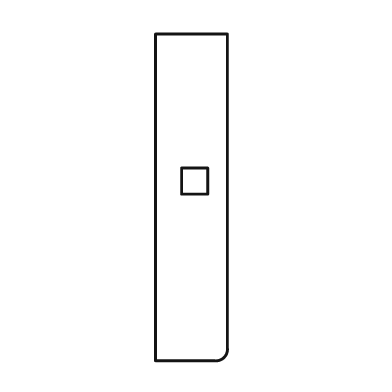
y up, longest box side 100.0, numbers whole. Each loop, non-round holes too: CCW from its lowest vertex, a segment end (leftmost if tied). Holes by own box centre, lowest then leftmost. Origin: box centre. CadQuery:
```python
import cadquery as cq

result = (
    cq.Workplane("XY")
    .moveTo(-11.0, -50.0)
    .lineTo(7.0, -50.0)
    .threePointArc((10.0, -49.0), (11.0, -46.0))
    .lineTo(11.0, 50.0)
    .lineTo(-11.0, 50.0)
    .close()
    .moveTo(-3.0, 1.0)
    .lineTo(5.0, 1.0)
    .lineTo(5.0, 9.0)
    .lineTo(-3.0, 9.0)
    .close()
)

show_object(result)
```